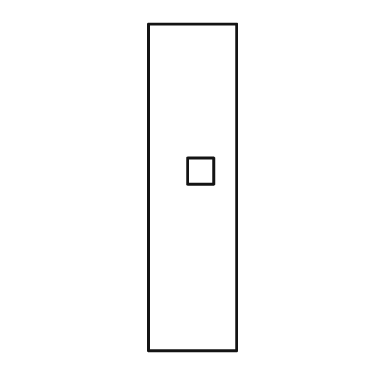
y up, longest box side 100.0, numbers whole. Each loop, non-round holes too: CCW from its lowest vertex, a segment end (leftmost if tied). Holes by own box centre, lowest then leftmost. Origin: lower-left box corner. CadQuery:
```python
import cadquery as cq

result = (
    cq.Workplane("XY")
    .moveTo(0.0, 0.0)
    .lineTo(27.0, 0.0)
    .lineTo(27.0, 100.0)
    .lineTo(0.0, 100.0)
    .close()
    .moveTo(12.0, 51.0)
    .lineTo(20.0, 51.0)
    .lineTo(20.0, 59.0)
    .lineTo(12.0, 59.0)
    .close()
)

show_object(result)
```